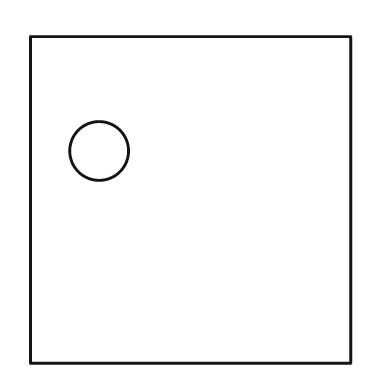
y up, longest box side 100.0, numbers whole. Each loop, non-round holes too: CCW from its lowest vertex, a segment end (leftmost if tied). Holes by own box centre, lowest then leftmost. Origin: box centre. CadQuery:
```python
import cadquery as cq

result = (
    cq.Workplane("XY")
    .moveTo(-49.0, -50.0)
    .lineTo(49.0, -50.0)
    .lineTo(49.0, 50.0)
    .lineTo(-49.0, 50.0)
    .close()
    .moveTo(-28.0, 15.0)
    .circle(9.0)
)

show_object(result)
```